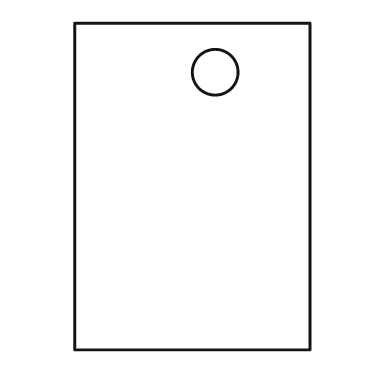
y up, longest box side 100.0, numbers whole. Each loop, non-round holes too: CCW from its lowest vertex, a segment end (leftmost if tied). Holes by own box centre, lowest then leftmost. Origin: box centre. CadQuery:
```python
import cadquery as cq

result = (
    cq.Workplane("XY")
    .moveTo(-36.0, -50.0)
    .lineTo(36.0, -50.0)
    .lineTo(36.0, 50.0)
    .lineTo(-36.0, 50.0)
    .close()
    .moveTo(7.0, 35.0)
    .circle(7.0)
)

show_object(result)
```